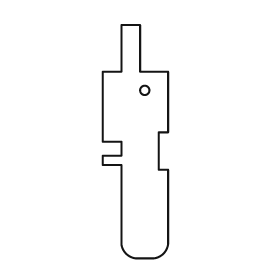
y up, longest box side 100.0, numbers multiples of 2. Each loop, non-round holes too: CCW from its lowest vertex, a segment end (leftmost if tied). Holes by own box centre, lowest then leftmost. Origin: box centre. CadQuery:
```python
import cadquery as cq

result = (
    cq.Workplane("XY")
    .moveTo(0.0, -50.0)
    .lineTo(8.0, -50.0)
    .threePointArc((12.0, -48.0), (14.0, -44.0))
    .lineTo(14.0, -12.0)
    .lineTo(10.0, -12.0)
    .lineTo(10.0, 4.0)
    .lineTo(14.0, 4.0)
    .lineTo(14.0, 30.0)
    .lineTo(2.0, 30.0)
    .lineTo(2.0, 50.0)
    .lineTo(-6.0, 50.0)
    .lineTo(-6.0, 30.0)
    .lineTo(-14.0, 30.0)
    .lineTo(-14.0, 0.0)
    .lineTo(-6.0, 0.0)
    .lineTo(-6.0, -6.0)
    .lineTo(-14.0, -6.0)
    .lineTo(-14.0, -10.0)
    .lineTo(-6.0, -10.0)
    .lineTo(-6.0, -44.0)
    .threePointArc((-4.0, -48.0), (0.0, -50.0))
    .close()
    .moveTo(4.0, 22.0)
    .circle(2.0)
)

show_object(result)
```